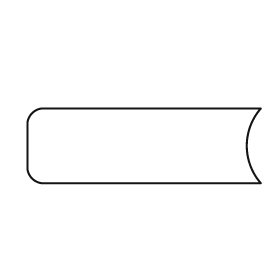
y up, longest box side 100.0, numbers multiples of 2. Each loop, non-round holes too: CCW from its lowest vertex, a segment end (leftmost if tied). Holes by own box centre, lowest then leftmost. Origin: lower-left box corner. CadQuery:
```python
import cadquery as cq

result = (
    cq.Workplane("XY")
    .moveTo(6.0, 0.0)
    .lineTo(100.0, 0.0)
    .threePointArc((94.0, 16.0), (100.0, 32.0))
    .lineTo(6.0, 32.0)
    .threePointArc((2.0, 30.0), (0.0, 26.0))
    .lineTo(0.0, 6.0)
    .threePointArc((2.0, 2.0), (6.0, 0.0))
    .close()
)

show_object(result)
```